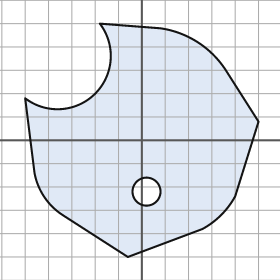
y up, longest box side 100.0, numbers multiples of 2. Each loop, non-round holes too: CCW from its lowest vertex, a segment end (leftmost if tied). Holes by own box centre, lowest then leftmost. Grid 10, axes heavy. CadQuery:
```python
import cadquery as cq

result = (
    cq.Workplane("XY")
    .moveTo(-6.0, -50.0)
    .lineTo(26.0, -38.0)
    .threePointArc((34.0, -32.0), (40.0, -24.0))
    .lineTo(50.0, 8.0)
    .lineTo(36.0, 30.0)
    .threePointArc((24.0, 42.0), (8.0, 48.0))
    .lineTo(-18.0, 50.0)
    .threePointArc((-20.0, 20.0), (-50.0, 18.0))
    .lineTo(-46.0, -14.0)
    .threePointArc((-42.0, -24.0), (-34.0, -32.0))
    .close()
    .moveTo(2.0, -22.0)
    .circle(6.0)
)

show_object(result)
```